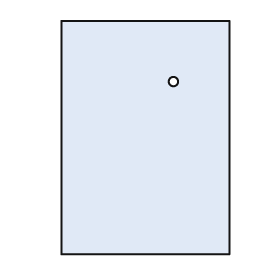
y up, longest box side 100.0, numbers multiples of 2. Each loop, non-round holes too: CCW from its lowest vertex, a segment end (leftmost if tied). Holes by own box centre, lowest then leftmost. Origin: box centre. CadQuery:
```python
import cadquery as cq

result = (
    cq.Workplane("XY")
    .moveTo(-36.0, -50.0)
    .lineTo(36.0, -50.0)
    .lineTo(36.0, 50.0)
    .lineTo(-36.0, 50.0)
    .close()
    .moveTo(12.0, 24.0)
    .circle(2.0)
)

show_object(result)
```